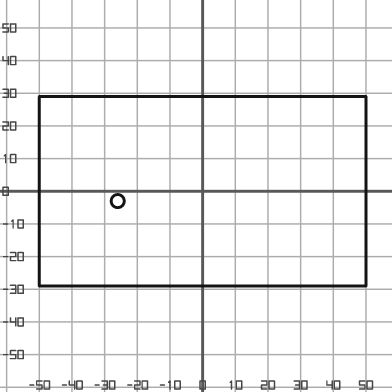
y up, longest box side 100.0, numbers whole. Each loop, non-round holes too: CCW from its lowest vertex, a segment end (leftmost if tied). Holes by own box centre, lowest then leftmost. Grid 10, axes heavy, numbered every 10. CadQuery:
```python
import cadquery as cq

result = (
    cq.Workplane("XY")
    .moveTo(-50.0, -29.0)
    .lineTo(50.0, -29.0)
    .lineTo(50.0, 29.0)
    .lineTo(-50.0, 29.0)
    .close()
    .moveTo(-26.0, -3.0)
    .circle(2.0)
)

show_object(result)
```